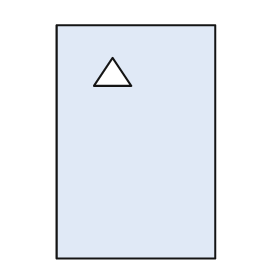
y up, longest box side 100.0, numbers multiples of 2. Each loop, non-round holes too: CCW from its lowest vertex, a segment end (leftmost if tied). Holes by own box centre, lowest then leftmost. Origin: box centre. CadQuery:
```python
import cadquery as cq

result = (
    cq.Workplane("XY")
    .moveTo(-34.0, -50.0)
    .lineTo(34.0, -50.0)
    .lineTo(34.0, 50.0)
    .lineTo(-34.0, 50.0)
    .close()
    .moveTo(-18.0, 24.0)
    .lineTo(-2.0, 24.0)
    .lineTo(-10.0, 36.0)
    .close()
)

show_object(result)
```